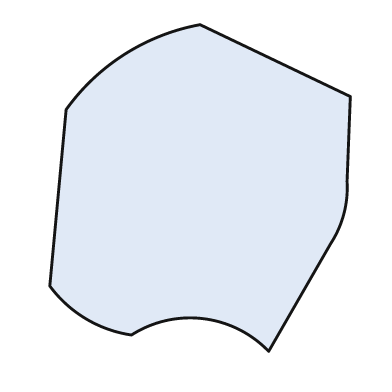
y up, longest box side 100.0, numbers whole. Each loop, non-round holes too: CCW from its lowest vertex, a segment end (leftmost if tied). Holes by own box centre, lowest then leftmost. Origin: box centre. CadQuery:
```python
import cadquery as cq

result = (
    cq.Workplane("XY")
    .moveTo(21.0, -50.0)
    .lineTo(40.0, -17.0)
    .threePointArc((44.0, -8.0), (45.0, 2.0))
    .lineTo(46.0, 28.0)
    .lineTo(0.0, 50.0)
    .threePointArc((-23.0, 41.0), (-41.0, 24.0))
    .lineTo(-46.0, -30.0)
    .threePointArc((-35.0, -40.0), (-21.0, -45.0))
    .threePointArc((1.0, -40.0), (21.0, -50.0))
    .close()
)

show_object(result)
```